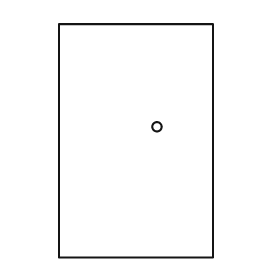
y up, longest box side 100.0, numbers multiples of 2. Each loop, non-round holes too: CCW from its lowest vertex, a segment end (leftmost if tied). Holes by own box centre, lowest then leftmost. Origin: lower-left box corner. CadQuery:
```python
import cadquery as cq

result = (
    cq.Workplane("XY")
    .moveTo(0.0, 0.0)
    .lineTo(66.0, 0.0)
    .lineTo(66.0, 100.0)
    .lineTo(0.0, 100.0)
    .close()
    .moveTo(42.0, 56.0)
    .circle(2.0)
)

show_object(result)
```